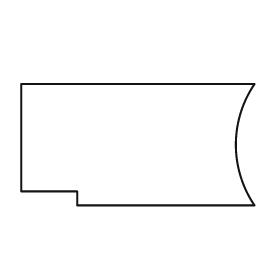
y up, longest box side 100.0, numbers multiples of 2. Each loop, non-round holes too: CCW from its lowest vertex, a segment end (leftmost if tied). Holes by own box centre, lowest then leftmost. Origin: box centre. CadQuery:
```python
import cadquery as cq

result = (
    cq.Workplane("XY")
    .moveTo(-26.0, -26.0)
    .lineTo(50.0, -26.0)
    .threePointArc((42.0, 0.0), (50.0, 26.0))
    .lineTo(-50.0, 26.0)
    .lineTo(-50.0, -20.0)
    .lineTo(-26.0, -20.0)
    .close()
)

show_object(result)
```